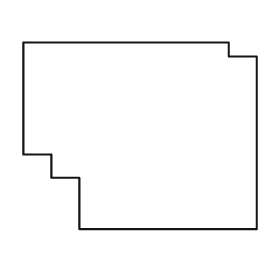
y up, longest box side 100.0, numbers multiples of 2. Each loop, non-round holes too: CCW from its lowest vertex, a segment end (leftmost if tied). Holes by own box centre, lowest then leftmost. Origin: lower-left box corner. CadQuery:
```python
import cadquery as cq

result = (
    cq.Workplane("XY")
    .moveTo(24.0, 0.0)
    .lineTo(100.0, 0.0)
    .lineTo(100.0, 74.0)
    .lineTo(88.0, 74.0)
    .lineTo(88.0, 80.0)
    .lineTo(0.0, 80.0)
    .lineTo(0.0, 32.0)
    .lineTo(12.0, 32.0)
    .lineTo(12.0, 22.0)
    .lineTo(24.0, 22.0)
    .close()
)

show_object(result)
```